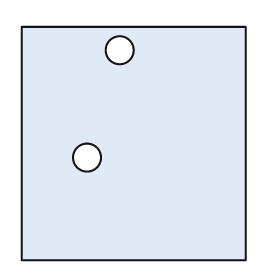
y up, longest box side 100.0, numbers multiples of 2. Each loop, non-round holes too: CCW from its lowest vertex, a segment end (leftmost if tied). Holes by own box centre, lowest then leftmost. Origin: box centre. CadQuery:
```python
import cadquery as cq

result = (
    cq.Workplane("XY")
    .moveTo(-48.0, -50.0)
    .lineTo(48.0, -50.0)
    .lineTo(48.0, 50.0)
    .lineTo(-48.0, 50.0)
    .close()
    .moveTo(-20.0, -6.0)
    .circle(6.0)
    .moveTo(-6.0, 40.0)
    .circle(6.0)
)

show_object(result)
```